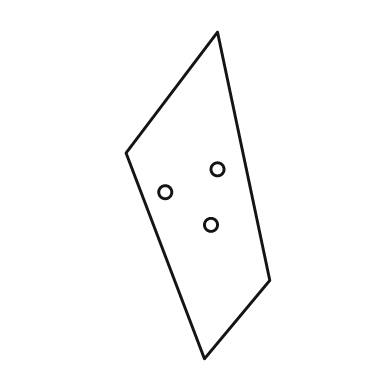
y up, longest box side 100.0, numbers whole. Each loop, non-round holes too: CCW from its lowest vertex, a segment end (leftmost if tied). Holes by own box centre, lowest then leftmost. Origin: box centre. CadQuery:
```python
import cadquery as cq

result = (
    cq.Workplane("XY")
    .moveTo(2.0, -50.0)
    .lineTo(22.0, -26.0)
    .lineTo(6.0, 50.0)
    .lineTo(-22.0, 13.0)
    .close()
    .moveTo(4.0, -9.0)
    .circle(2.0)
    .moveTo(-10.0, 1.0)
    .circle(2.0)
    .moveTo(6.0, 8.0)
    .circle(2.0)
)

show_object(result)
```